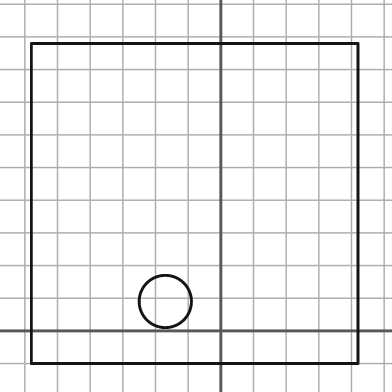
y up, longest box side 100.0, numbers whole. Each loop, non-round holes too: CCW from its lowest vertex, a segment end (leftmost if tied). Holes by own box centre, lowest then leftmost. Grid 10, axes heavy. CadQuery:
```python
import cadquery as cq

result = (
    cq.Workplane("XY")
    .moveTo(-58.0, -10.0)
    .lineTo(42.0, -10.0)
    .lineTo(42.0, 88.0)
    .lineTo(-58.0, 88.0)
    .close()
    .moveTo(-17.0, 9.0)
    .circle(8.0)
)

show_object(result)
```